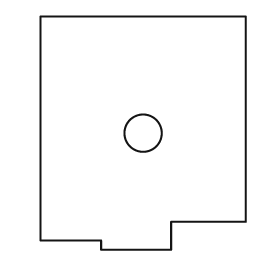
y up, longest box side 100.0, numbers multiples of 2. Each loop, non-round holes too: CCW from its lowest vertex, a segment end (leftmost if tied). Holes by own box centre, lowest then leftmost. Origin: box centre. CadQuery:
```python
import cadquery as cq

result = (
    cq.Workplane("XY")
    .moveTo(-18.0, -50.0)
    .lineTo(12.0, -50.0)
    .lineTo(12.0, -38.0)
    .lineTo(44.0, -38.0)
    .lineTo(44.0, 50.0)
    .lineTo(-44.0, 50.0)
    .lineTo(-44.0, -46.0)
    .lineTo(-18.0, -46.0)
    .close()
    .moveTo(0.0, 0.0)
    .circle(8.0)
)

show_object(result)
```